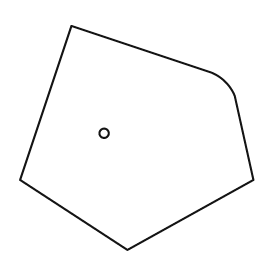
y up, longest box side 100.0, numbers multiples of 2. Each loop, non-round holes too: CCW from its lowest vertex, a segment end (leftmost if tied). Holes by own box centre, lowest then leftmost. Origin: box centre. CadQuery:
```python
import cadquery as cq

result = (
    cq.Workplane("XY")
    .moveTo(-4.0, -48.0)
    .lineTo(50.0, -18.0)
    .lineTo(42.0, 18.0)
    .threePointArc((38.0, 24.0), (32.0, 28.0))
    .lineTo(-28.0, 48.0)
    .lineTo(-50.0, -18.0)
    .close()
    .moveTo(-14.0, 2.0)
    .circle(2.0)
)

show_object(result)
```